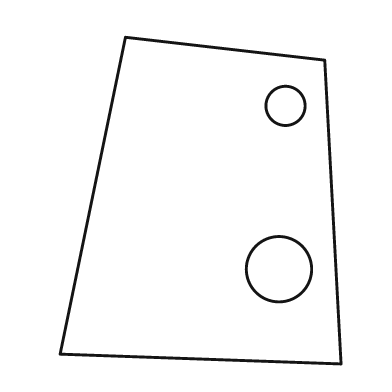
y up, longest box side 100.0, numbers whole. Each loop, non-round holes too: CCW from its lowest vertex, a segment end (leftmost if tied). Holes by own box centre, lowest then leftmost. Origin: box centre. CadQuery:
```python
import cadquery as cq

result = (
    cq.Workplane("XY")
    .moveTo(43.0, -50.0)
    .lineTo(38.0, 43.0)
    .lineTo(-23.0, 50.0)
    .lineTo(-43.0, -47.0)
    .close()
    .moveTo(24.0, -21.0)
    .circle(10.0)
    .moveTo(26.0, 29.0)
    .circle(6.0)
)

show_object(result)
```